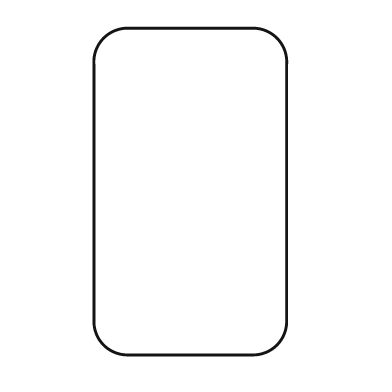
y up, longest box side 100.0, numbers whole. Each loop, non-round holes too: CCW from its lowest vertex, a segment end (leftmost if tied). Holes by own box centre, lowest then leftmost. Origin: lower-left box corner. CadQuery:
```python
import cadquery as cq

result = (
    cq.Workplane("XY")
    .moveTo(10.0, 0.0)
    .lineTo(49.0, 0.0)
    .threePointArc((56.0, 3.0), (59.0, 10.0))
    .lineTo(59.0, 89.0)
    .threePointArc((56.0, 97.0), (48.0, 100.0))
    .lineTo(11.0, 100.0)
    .threePointArc((3.0, 97.0), (0.0, 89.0))
    .lineTo(0.0, 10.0)
    .threePointArc((3.0, 3.0), (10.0, 0.0))
    .close()
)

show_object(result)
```